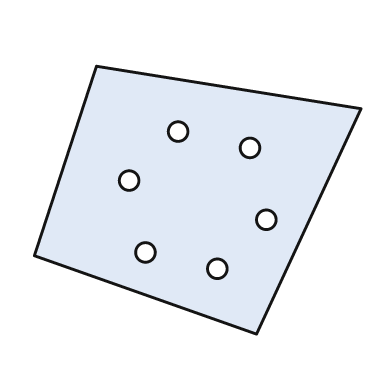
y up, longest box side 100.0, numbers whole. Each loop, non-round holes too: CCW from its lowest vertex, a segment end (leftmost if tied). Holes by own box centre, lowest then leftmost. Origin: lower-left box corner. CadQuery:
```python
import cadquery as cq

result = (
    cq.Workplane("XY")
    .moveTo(68.0, 0.0)
    .lineTo(100.0, 69.0)
    .lineTo(19.0, 82.0)
    .lineTo(0.0, 24.0)
    .close()
    .moveTo(56.0, 20.0)
    .circle(3.0)
    .moveTo(34.0, 25.0)
    .circle(3.0)
    .moveTo(71.0, 35.0)
    .circle(3.0)
    .moveTo(29.0, 47.0)
    .circle(3.0)
    .moveTo(66.0, 57.0)
    .circle(3.0)
    .moveTo(44.0, 62.0)
    .circle(3.0)
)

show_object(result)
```